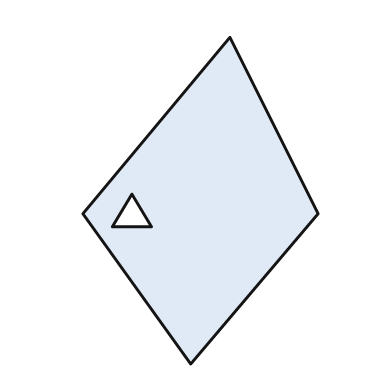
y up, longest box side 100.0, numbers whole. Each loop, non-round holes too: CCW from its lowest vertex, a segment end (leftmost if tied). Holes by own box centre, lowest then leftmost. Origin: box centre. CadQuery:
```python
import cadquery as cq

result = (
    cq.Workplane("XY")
    .moveTo(-3.0, -50.0)
    .lineTo(36.0, -4.0)
    .lineTo(9.0, 50.0)
    .lineTo(-36.0, -4.0)
    .close()
    .moveTo(-27.0, -8.0)
    .lineTo(-15.0, -8.0)
    .lineTo(-21.0, 2.0)
    .close()
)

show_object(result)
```